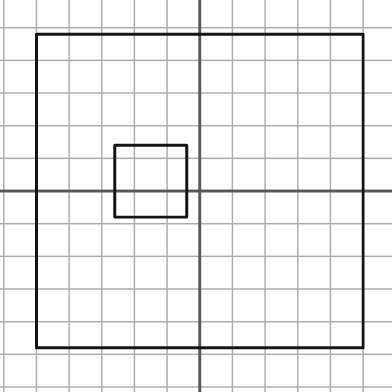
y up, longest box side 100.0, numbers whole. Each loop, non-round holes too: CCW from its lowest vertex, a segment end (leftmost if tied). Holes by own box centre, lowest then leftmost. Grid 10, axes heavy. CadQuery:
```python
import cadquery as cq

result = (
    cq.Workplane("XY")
    .moveTo(-50.0, -48.0)
    .lineTo(50.0, -48.0)
    .lineTo(50.0, 48.0)
    .lineTo(-50.0, 48.0)
    .close()
    .moveTo(-26.0, -8.0)
    .lineTo(-4.0, -8.0)
    .lineTo(-4.0, 14.0)
    .lineTo(-26.0, 14.0)
    .close()
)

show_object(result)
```